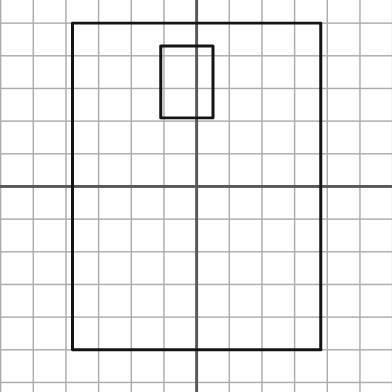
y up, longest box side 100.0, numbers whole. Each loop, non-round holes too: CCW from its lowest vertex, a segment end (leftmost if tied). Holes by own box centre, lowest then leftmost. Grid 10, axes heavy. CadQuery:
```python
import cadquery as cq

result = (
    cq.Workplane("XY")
    .moveTo(-38.0, -50.0)
    .lineTo(38.0, -50.0)
    .lineTo(38.0, 50.0)
    .lineTo(-38.0, 50.0)
    .close()
    .moveTo(-11.0, 21.0)
    .lineTo(5.0, 21.0)
    .lineTo(5.0, 43.0)
    .lineTo(-11.0, 43.0)
    .close()
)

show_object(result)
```